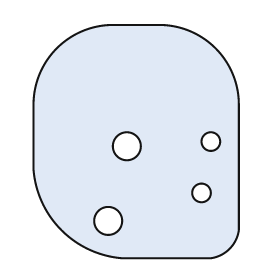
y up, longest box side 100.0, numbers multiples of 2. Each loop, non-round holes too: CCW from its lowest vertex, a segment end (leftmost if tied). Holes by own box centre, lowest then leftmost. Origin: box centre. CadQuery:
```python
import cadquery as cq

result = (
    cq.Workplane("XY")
    .moveTo(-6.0, -50.0)
    .lineTo(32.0, -50.0)
    .threePointArc((40.0, -46.0), (44.0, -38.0))
    .lineTo(44.0, 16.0)
    .threePointArc((34.0, 40.0), (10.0, 50.0))
    .lineTo(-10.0, 50.0)
    .threePointArc((-34.0, 40.0), (-44.0, 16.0))
    .lineTo(-44.0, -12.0)
    .threePointArc((-32.0, -38.0), (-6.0, -50.0))
    .close()
    .moveTo(-12.0, -34.0)
    .circle(6.0)
    .moveTo(28.0, -22.0)
    .circle(4.0)
    .moveTo(-4.0, -2.0)
    .circle(6.0)
    .moveTo(32.0, 0.0)
    .circle(4.0)
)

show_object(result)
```